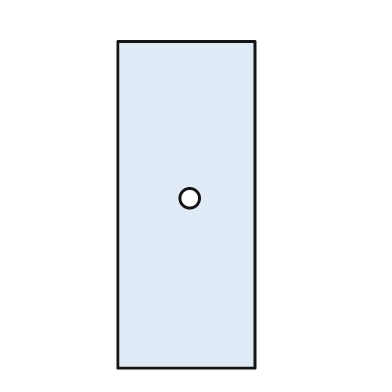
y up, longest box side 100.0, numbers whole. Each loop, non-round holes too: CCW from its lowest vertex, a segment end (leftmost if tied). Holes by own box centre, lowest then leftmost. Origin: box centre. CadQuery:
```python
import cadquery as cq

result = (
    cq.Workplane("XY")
    .moveTo(-21.0, -50.0)
    .lineTo(21.0, -50.0)
    .lineTo(21.0, 50.0)
    .lineTo(-21.0, 50.0)
    .close()
    .moveTo(1.0, 2.0)
    .circle(3.0)
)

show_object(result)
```